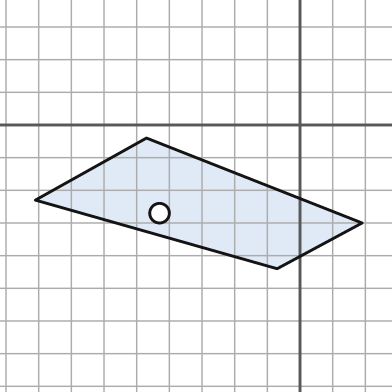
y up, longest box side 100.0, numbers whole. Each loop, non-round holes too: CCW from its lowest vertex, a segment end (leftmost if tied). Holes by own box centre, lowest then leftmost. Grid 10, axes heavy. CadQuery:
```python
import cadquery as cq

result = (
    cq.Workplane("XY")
    .moveTo(-7.0, -44.0)
    .lineTo(19.0, -30.0)
    .lineTo(-47.0, -4.0)
    .lineTo(-81.0, -23.0)
    .close()
    .moveTo(-43.0, -27.0)
    .circle(3.0)
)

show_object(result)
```